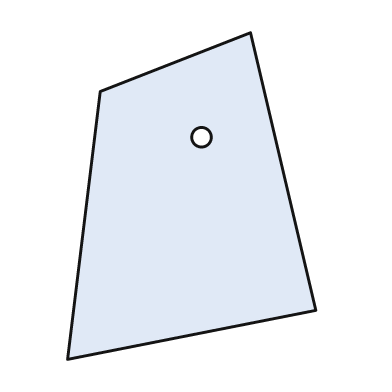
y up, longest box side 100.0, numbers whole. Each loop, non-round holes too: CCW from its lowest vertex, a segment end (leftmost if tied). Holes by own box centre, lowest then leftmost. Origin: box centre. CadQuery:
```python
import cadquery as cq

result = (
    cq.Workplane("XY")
    .moveTo(-38.0, -50.0)
    .lineTo(38.0, -35.0)
    .lineTo(18.0, 50.0)
    .lineTo(-28.0, 32.0)
    .close()
    .moveTo(3.0, 18.0)
    .circle(3.0)
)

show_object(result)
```